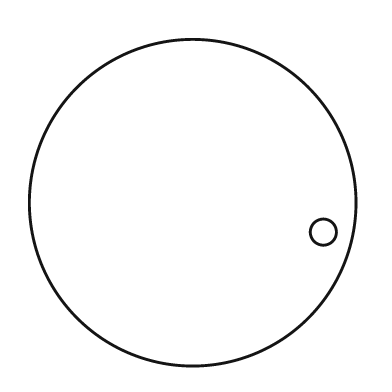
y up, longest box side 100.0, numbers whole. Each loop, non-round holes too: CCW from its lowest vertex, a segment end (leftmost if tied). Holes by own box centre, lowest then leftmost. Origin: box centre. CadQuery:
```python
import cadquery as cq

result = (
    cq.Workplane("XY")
    .moveTo(0.0, 0.0)
    .circle(50.0)
    .moveTo(40.0, -9.0)
    .circle(4.0)
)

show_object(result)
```